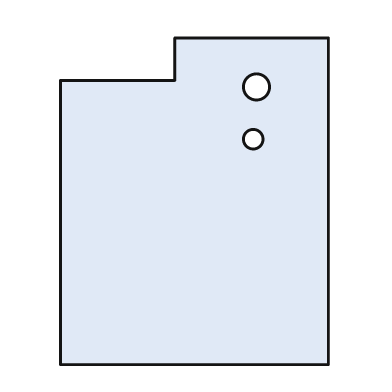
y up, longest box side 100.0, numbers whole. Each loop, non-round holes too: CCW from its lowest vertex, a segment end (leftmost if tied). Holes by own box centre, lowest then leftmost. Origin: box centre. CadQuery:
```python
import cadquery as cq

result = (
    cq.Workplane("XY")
    .moveTo(-41.0, -50.0)
    .lineTo(41.0, -50.0)
    .lineTo(41.0, 50.0)
    .lineTo(-6.0, 50.0)
    .lineTo(-6.0, 37.0)
    .lineTo(-41.0, 37.0)
    .close()
    .moveTo(18.0, 19.0)
    .circle(3.0)
    .moveTo(19.0, 35.0)
    .circle(4.0)
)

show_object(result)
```